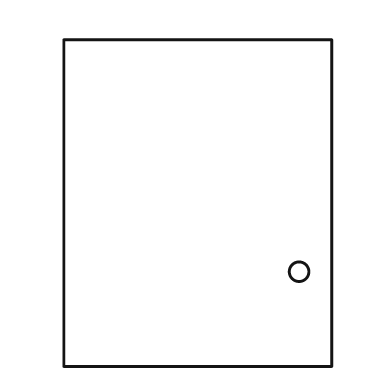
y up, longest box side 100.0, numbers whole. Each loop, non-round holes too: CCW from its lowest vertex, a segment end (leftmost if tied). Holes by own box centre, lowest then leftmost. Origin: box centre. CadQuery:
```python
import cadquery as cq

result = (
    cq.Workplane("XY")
    .moveTo(-41.0, -50.0)
    .lineTo(41.0, -50.0)
    .lineTo(41.0, 50.0)
    .lineTo(-41.0, 50.0)
    .close()
    .moveTo(31.0, -21.0)
    .circle(3.0)
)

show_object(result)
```